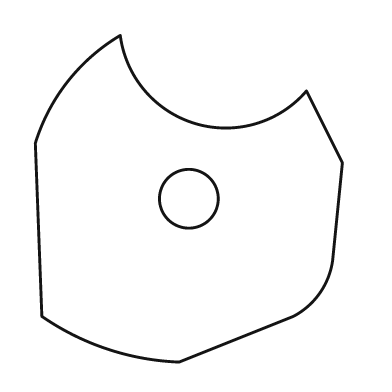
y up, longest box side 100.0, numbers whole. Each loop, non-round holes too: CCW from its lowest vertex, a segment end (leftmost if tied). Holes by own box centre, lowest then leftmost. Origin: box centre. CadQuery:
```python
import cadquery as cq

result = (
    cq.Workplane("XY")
    .moveTo(-3.0, -50.0)
    .lineTo(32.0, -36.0)
    .threePointArc((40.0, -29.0), (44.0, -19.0))
    .lineTo(47.0, 11.0)
    .lineTo(36.0, 33.0)
    .threePointArc((2.0, 23.0), (-21.0, 50.0))
    .threePointArc((-37.0, 36.0), (-47.0, 17.0))
    .lineTo(-45.0, -36.0)
    .threePointArc((-25.0, -46.0), (-3.0, -50.0))
    .close()
    .moveTo(0.0, 0.0)
    .circle(9.0)
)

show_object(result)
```